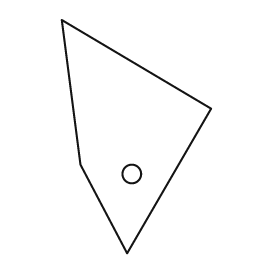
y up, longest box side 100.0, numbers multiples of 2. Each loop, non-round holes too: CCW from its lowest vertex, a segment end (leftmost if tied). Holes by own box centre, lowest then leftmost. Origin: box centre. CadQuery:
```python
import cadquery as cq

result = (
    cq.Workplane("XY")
    .moveTo(-4.0, -50.0)
    .lineTo(32.0, 12.0)
    .lineTo(-32.0, 50.0)
    .lineTo(-24.0, -12.0)
    .close()
    .moveTo(-2.0, -16.0)
    .circle(4.0)
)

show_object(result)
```